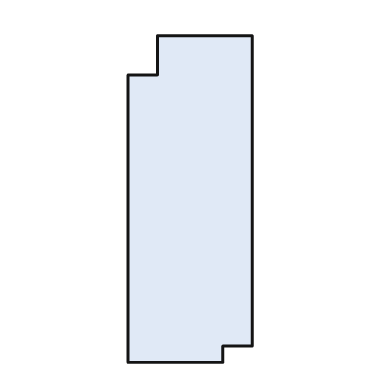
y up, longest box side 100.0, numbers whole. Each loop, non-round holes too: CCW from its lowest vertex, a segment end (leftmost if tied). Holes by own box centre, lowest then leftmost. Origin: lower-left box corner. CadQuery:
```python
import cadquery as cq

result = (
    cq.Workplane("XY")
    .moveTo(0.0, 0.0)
    .lineTo(29.0, 0.0)
    .lineTo(29.0, 5.0)
    .lineTo(38.0, 5.0)
    .lineTo(38.0, 100.0)
    .lineTo(9.0, 100.0)
    .lineTo(9.0, 88.0)
    .lineTo(0.0, 88.0)
    .close()
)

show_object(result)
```